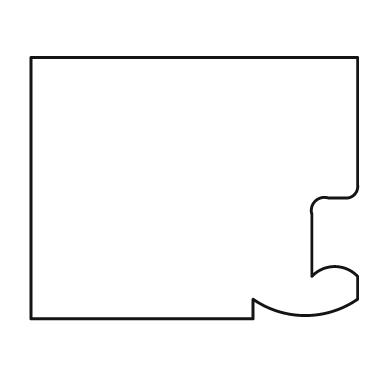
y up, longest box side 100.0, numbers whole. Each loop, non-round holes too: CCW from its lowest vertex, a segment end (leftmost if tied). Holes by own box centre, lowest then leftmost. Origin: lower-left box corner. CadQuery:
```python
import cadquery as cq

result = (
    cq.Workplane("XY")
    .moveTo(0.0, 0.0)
    .lineTo(68.0, 0.0)
    .lineTo(68.0, 6.0)
    .threePointArc((84.0, 1.0), (100.0, 6.0))
    .lineTo(100.0, 13.0)
    .threePointArc((93.0, 16.0), (86.0, 13.0))
    .lineTo(86.0, 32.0)
    .threePointArc((87.0, 36.0), (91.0, 37.0))
    .lineTo(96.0, 37.0)
    .threePointArc((99.0, 38.0), (100.0, 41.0))
    .lineTo(100.0, 80.0)
    .lineTo(0.0, 80.0)
    .close()
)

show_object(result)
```